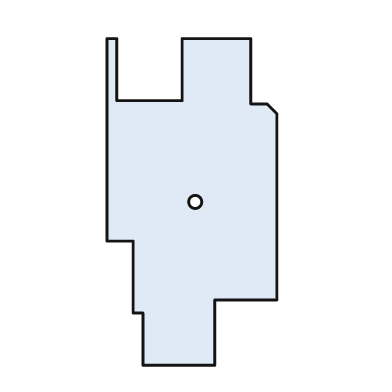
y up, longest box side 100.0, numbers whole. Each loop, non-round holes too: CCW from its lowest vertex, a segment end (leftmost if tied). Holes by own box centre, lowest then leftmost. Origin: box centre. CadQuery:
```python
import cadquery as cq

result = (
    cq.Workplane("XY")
    .moveTo(-15.0, -50.0)
    .lineTo(7.0, -50.0)
    .lineTo(7.0, -30.0)
    .lineTo(26.0, -30.0)
    .lineTo(26.0, 27.0)
    .lineTo(23.0, 30.0)
    .lineTo(18.0, 30.0)
    .lineTo(18.0, 50.0)
    .lineTo(-3.0, 50.0)
    .lineTo(-3.0, 31.0)
    .lineTo(-23.0, 31.0)
    .lineTo(-23.0, 50.0)
    .lineTo(-26.0, 50.0)
    .lineTo(-26.0, -12.0)
    .lineTo(-18.0, -12.0)
    .lineTo(-18.0, -34.0)
    .lineTo(-15.0, -34.0)
    .close()
    .moveTo(1.0, 0.0)
    .circle(2.0)
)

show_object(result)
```